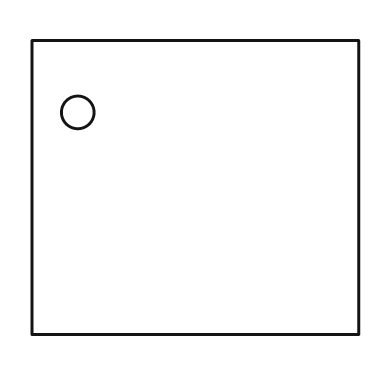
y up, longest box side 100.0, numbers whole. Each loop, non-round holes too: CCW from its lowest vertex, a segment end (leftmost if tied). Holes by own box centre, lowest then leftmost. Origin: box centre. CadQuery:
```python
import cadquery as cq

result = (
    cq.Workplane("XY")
    .moveTo(-50.0, -45.0)
    .lineTo(50.0, -45.0)
    .lineTo(50.0, 45.0)
    .lineTo(-50.0, 45.0)
    .close()
    .moveTo(-36.0, 23.0)
    .circle(5.0)
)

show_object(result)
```